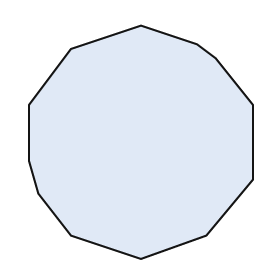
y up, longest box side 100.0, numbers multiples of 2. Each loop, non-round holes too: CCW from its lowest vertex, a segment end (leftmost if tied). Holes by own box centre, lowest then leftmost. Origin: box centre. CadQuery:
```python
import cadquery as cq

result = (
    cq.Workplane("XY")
    .moveTo(0.0, -50.0)
    .lineTo(28.0, -40.0)
    .lineTo(48.0, -16.0)
    .lineTo(48.0, 16.0)
    .lineTo(32.0, 36.0)
    .lineTo(24.0, 42.0)
    .lineTo(0.0, 50.0)
    .lineTo(-30.0, 40.0)
    .lineTo(-48.0, 16.0)
    .lineTo(-48.0, -8.0)
    .lineTo(-44.0, -22.0)
    .lineTo(-30.0, -40.0)
    .close()
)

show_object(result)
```